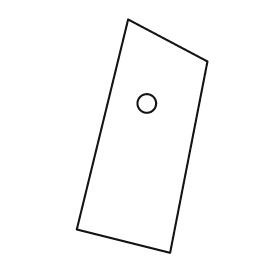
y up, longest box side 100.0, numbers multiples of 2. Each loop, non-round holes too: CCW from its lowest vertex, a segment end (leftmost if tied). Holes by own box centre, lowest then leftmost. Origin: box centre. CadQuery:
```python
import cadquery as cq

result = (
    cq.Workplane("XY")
    .moveTo(12.0, -50.0)
    .lineTo(28.0, 32.0)
    .lineTo(-6.0, 50.0)
    .lineTo(-28.0, -40.0)
    .close()
    .moveTo(2.0, 14.0)
    .circle(4.0)
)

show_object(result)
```